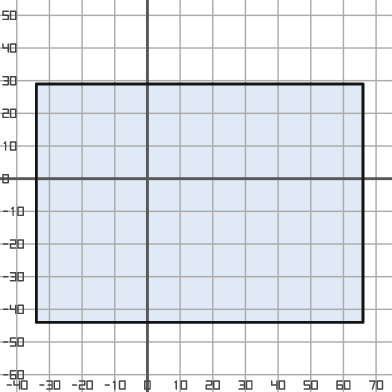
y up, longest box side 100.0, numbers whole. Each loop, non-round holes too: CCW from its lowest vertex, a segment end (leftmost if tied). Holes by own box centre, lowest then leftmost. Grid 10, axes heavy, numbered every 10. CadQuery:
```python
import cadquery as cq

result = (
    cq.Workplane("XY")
    .moveTo(-34.0, -44.0)
    .lineTo(66.0, -44.0)
    .lineTo(66.0, 29.0)
    .lineTo(-34.0, 29.0)
    .close()
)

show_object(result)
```